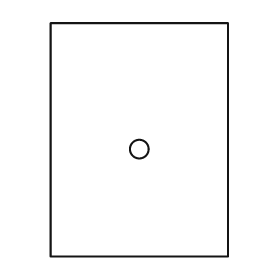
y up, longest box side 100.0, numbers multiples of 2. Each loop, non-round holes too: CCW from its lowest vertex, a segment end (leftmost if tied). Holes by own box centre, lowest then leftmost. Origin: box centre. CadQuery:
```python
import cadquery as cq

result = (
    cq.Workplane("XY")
    .moveTo(-38.0, -50.0)
    .lineTo(38.0, -50.0)
    .lineTo(38.0, 50.0)
    .lineTo(-38.0, 50.0)
    .close()
    .moveTo(0.0, -4.0)
    .circle(4.0)
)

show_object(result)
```